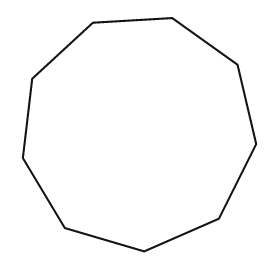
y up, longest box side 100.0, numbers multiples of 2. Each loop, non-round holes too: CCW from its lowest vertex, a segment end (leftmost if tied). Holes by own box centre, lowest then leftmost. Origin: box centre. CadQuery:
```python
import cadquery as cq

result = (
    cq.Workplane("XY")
    .moveTo(2.0, -50.0)
    .lineTo(34.0, -36.0)
    .lineTo(50.0, -4.0)
    .lineTo(42.0, 30.0)
    .lineTo(14.0, 50.0)
    .lineTo(-20.0, 48.0)
    .lineTo(-46.0, 24.0)
    .lineTo(-50.0, -10.0)
    .lineTo(-32.0, -40.0)
    .close()
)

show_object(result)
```